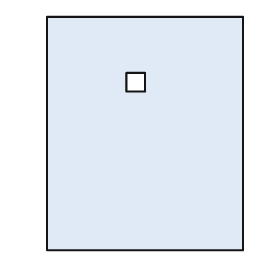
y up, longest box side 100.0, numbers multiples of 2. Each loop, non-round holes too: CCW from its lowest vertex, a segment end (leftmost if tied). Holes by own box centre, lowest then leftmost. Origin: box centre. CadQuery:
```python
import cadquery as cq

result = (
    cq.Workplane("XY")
    .moveTo(-42.0, -50.0)
    .lineTo(42.0, -50.0)
    .lineTo(42.0, 50.0)
    .lineTo(-42.0, 50.0)
    .close()
    .moveTo(-8.0, 18.0)
    .lineTo(0.0, 18.0)
    .lineTo(0.0, 26.0)
    .lineTo(-8.0, 26.0)
    .close()
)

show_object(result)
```